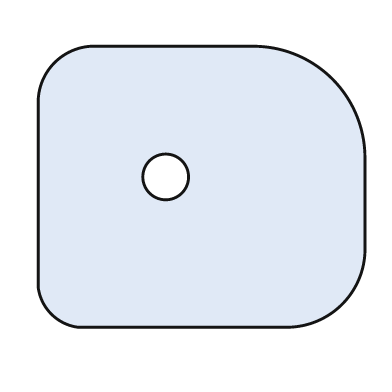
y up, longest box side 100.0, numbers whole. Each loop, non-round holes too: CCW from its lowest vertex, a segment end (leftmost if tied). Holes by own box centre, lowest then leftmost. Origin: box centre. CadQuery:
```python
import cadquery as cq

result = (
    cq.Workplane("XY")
    .moveTo(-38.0, -43.0)
    .lineTo(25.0, -43.0)
    .threePointArc((43.0, -36.0), (50.0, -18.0))
    .lineTo(50.0, 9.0)
    .threePointArc((40.0, 33.0), (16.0, 43.0))
    .lineTo(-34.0, 43.0)
    .threePointArc((-45.0, 38.0), (-50.0, 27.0))
    .lineTo(-50.0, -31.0)
    .threePointArc((-46.0, -39.0), (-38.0, -43.0))
    .close()
    .moveTo(-11.0, 3.0)
    .circle(7.0)
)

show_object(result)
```